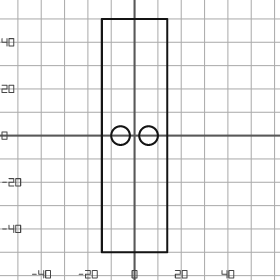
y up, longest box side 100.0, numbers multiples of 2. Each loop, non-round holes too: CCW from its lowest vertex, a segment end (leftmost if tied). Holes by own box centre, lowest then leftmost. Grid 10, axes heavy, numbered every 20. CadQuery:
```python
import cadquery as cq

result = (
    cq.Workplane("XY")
    .moveTo(-14.0, -50.0)
    .lineTo(14.0, -50.0)
    .lineTo(14.0, 50.0)
    .lineTo(-14.0, 50.0)
    .close()
    .moveTo(-6.0, 0.0)
    .circle(4.0)
    .moveTo(6.0, 0.0)
    .circle(4.0)
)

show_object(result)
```